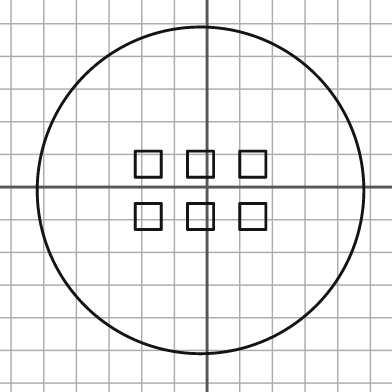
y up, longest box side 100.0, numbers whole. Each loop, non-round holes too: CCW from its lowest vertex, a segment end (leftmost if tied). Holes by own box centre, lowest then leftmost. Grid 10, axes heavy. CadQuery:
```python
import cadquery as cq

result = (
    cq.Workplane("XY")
    .moveTo(-2.0, -1.0)
    .circle(50.0)
    .moveTo(-22.0, -13.0)
    .lineTo(-14.0, -13.0)
    .lineTo(-14.0, -5.0)
    .lineTo(-22.0, -5.0)
    .close()
    .moveTo(-6.0, -13.0)
    .lineTo(2.0, -13.0)
    .lineTo(2.0, -5.0)
    .lineTo(-6.0, -5.0)
    .close()
    .moveTo(10.0, -13.0)
    .lineTo(18.0, -13.0)
    .lineTo(18.0, -5.0)
    .lineTo(10.0, -5.0)
    .close()
    .moveTo(-22.0, 3.0)
    .lineTo(-14.0, 3.0)
    .lineTo(-14.0, 11.0)
    .lineTo(-22.0, 11.0)
    .close()
    .moveTo(-6.0, 3.0)
    .lineTo(2.0, 3.0)
    .lineTo(2.0, 11.0)
    .lineTo(-6.0, 11.0)
    .close()
    .moveTo(10.0, 3.0)
    .lineTo(18.0, 3.0)
    .lineTo(18.0, 11.0)
    .lineTo(10.0, 11.0)
    .close()
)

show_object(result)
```